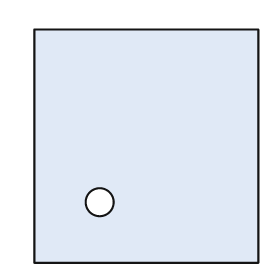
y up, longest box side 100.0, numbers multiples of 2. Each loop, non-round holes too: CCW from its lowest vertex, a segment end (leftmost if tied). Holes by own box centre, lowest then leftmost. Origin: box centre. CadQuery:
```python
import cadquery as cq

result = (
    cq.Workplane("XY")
    .moveTo(-48.0, -50.0)
    .lineTo(48.0, -50.0)
    .lineTo(48.0, 50.0)
    .lineTo(-48.0, 50.0)
    .close()
    .moveTo(-20.0, -24.0)
    .circle(6.0)
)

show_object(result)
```